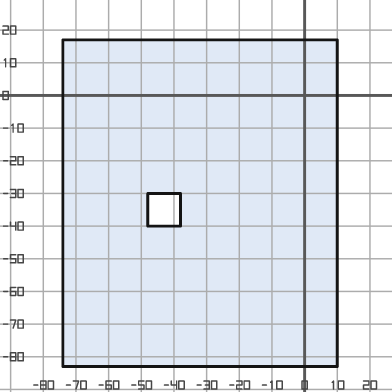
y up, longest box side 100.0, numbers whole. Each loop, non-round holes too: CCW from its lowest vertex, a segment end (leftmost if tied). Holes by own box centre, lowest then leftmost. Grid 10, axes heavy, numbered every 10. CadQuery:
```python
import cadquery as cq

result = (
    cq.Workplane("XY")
    .moveTo(-74.0, -83.0)
    .lineTo(10.0, -83.0)
    .lineTo(10.0, 17.0)
    .lineTo(-74.0, 17.0)
    .close()
    .moveTo(-48.0, -40.0)
    .lineTo(-38.0, -40.0)
    .lineTo(-38.0, -30.0)
    .lineTo(-48.0, -30.0)
    .close()
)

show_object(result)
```